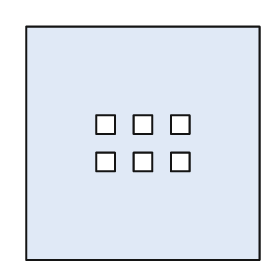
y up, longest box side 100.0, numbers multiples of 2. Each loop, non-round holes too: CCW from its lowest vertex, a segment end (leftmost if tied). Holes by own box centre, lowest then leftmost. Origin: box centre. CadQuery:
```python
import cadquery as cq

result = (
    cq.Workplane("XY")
    .moveTo(-50.0, -50.0)
    .lineTo(50.0, -50.0)
    .lineTo(50.0, 50.0)
    .lineTo(-50.0, 50.0)
    .close()
    .moveTo(-20.0, -12.0)
    .lineTo(-12.0, -12.0)
    .lineTo(-12.0, -4.0)
    .lineTo(-20.0, -4.0)
    .close()
    .moveTo(-4.0, -12.0)
    .lineTo(4.0, -12.0)
    .lineTo(4.0, -4.0)
    .lineTo(-4.0, -4.0)
    .close()
    .moveTo(12.0, -12.0)
    .lineTo(20.0, -12.0)
    .lineTo(20.0, -4.0)
    .lineTo(12.0, -4.0)
    .close()
    .moveTo(-20.0, 4.0)
    .lineTo(-12.0, 4.0)
    .lineTo(-12.0, 12.0)
    .lineTo(-20.0, 12.0)
    .close()
    .moveTo(-4.0, 4.0)
    .lineTo(4.0, 4.0)
    .lineTo(4.0, 12.0)
    .lineTo(-4.0, 12.0)
    .close()
    .moveTo(12.0, 4.0)
    .lineTo(20.0, 4.0)
    .lineTo(20.0, 12.0)
    .lineTo(12.0, 12.0)
    .close()
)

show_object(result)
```